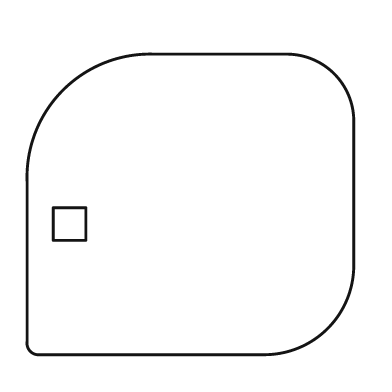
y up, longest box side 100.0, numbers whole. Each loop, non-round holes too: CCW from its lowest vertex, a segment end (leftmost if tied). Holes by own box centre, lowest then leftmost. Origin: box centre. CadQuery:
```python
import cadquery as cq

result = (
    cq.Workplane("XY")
    .moveTo(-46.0, -46.0)
    .lineTo(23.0, -46.0)
    .threePointArc((42.0, -38.0), (50.0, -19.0))
    .lineTo(50.0, 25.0)
    .threePointArc((44.0, 40.0), (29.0, 46.0))
    .lineTo(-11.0, 46.0)
    .threePointArc((-39.0, 35.0), (-50.0, 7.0))
    .lineTo(-50.0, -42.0)
    .threePointArc((-49.0, -45.0), (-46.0, -46.0))
    .close()
    .moveTo(-42.0, -11.0)
    .lineTo(-32.0, -11.0)
    .lineTo(-32.0, -1.0)
    .lineTo(-42.0, -1.0)
    .close()
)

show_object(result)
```